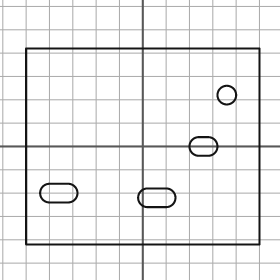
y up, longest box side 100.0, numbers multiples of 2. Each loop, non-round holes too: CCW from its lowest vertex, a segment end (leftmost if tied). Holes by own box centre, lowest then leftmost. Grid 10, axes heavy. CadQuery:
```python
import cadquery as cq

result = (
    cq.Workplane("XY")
    .moveTo(-50.0, -42.0)
    .lineTo(50.0, -42.0)
    .lineTo(50.0, 42.0)
    .lineTo(-50.0, 42.0)
    .close()
    .moveTo(2.0, -26.0)
    .lineTo(10.0, -26.0)
    .threePointArc((14.0, -22.0), (10.0, -18.0))
    .lineTo(2.0, -18.0)
    .threePointArc((-2.0, -22.0), (2.0, -26.0))
    .close()
    .moveTo(-40.0, -24.0)
    .lineTo(-32.0, -24.0)
    .threePointArc((-28.0, -20.0), (-32.0, -16.0))
    .lineTo(-40.0, -16.0)
    .threePointArc((-44.0, -20.0), (-40.0, -24.0))
    .close()
    .moveTo(24.0, -4.0)
    .lineTo(28.0, -4.0)
    .threePointArc((32.0, 0.0), (28.0, 4.0))
    .lineTo(24.0, 4.0)
    .threePointArc((20.0, 0.0), (24.0, -4.0))
    .close()
    .moveTo(36.0, 22.0)
    .circle(4.0)
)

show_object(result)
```